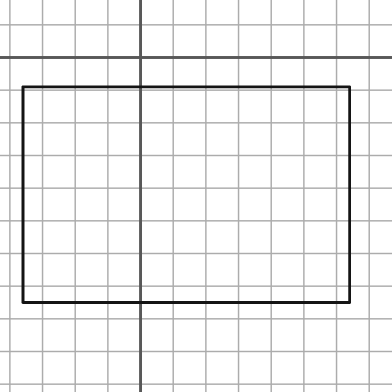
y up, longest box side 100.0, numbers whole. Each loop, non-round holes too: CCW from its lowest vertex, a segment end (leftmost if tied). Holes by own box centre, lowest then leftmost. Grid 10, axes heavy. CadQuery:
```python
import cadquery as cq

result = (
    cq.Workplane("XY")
    .moveTo(-36.0, -75.0)
    .lineTo(64.0, -75.0)
    .lineTo(64.0, -9.0)
    .lineTo(-36.0, -9.0)
    .close()
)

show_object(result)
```